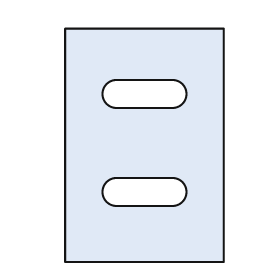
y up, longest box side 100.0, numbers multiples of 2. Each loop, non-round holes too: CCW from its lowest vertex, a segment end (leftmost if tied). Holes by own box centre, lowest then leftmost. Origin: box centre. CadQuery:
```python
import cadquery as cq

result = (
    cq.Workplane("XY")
    .moveTo(-34.0, -50.0)
    .lineTo(34.0, -50.0)
    .lineTo(34.0, 50.0)
    .lineTo(-34.0, 50.0)
    .close()
    .moveTo(-12.0, -26.0)
    .lineTo(12.0, -26.0)
    .threePointArc((18.0, -20.0), (12.0, -14.0))
    .lineTo(-12.0, -14.0)
    .threePointArc((-18.0, -20.0), (-12.0, -26.0))
    .close()
    .moveTo(-12.0, 16.0)
    .lineTo(12.0, 16.0)
    .threePointArc((18.0, 22.0), (12.0, 28.0))
    .lineTo(-12.0, 28.0)
    .threePointArc((-18.0, 22.0), (-12.0, 16.0))
    .close()
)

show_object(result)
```